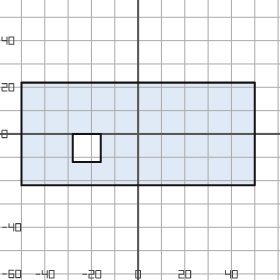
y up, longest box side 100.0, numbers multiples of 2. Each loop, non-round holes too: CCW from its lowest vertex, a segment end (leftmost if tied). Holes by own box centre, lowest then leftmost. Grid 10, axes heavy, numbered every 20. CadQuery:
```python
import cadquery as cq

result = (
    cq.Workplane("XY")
    .moveTo(-50.0, -22.0)
    .lineTo(50.0, -22.0)
    .lineTo(50.0, 22.0)
    .lineTo(-50.0, 22.0)
    .close()
    .moveTo(-28.0, -12.0)
    .lineTo(-16.0, -12.0)
    .lineTo(-16.0, 0.0)
    .lineTo(-28.0, 0.0)
    .close()
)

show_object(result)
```